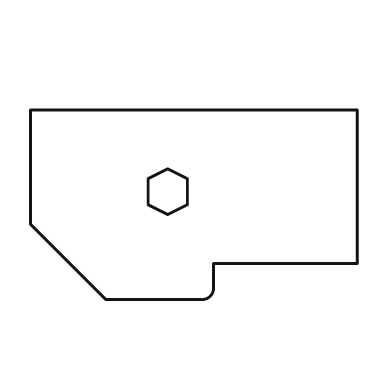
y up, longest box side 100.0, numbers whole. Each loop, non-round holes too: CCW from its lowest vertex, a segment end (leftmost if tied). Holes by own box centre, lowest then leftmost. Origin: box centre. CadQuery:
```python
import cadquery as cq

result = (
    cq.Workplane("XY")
    .moveTo(-27.0, -29.0)
    .lineTo(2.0, -29.0)
    .threePointArc((5.0, -28.0), (6.0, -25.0))
    .lineTo(6.0, -18.0)
    .lineTo(50.0, -18.0)
    .lineTo(50.0, 29.0)
    .lineTo(-50.0, 29.0)
    .lineTo(-50.0, -6.0)
    .close()
    .moveTo(-8.0, -3.0)
    .lineTo(-2.0, 0.0)
    .lineTo(-2.0, 8.0)
    .lineTo(-8.0, 11.0)
    .lineTo(-14.0, 8.0)
    .lineTo(-14.0, 0.0)
    .close()
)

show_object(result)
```